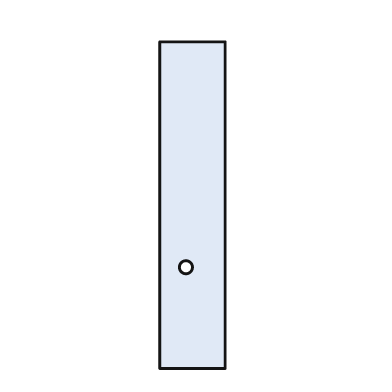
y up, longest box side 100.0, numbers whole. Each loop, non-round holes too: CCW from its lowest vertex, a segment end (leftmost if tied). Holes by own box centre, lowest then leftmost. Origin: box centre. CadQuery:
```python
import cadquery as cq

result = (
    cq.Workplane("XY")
    .moveTo(-10.0, -50.0)
    .lineTo(10.0, -50.0)
    .lineTo(10.0, 50.0)
    .lineTo(-10.0, 50.0)
    .close()
    .moveTo(-2.0, -19.0)
    .circle(2.0)
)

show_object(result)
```